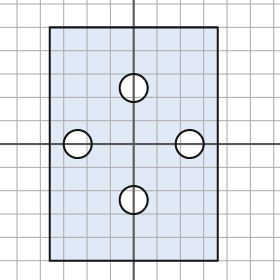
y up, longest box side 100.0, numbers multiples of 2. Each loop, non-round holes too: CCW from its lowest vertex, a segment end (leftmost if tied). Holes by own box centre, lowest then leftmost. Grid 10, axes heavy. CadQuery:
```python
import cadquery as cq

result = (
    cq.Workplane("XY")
    .moveTo(-36.0, -50.0)
    .lineTo(36.0, -50.0)
    .lineTo(36.0, 50.0)
    .lineTo(-36.0, 50.0)
    .close()
    .moveTo(0.0, -24.0)
    .circle(6.0)
    .moveTo(-24.0, 0.0)
    .circle(6.0)
    .moveTo(24.0, 0.0)
    .circle(6.0)
    .moveTo(0.0, 24.0)
    .circle(6.0)
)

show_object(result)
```